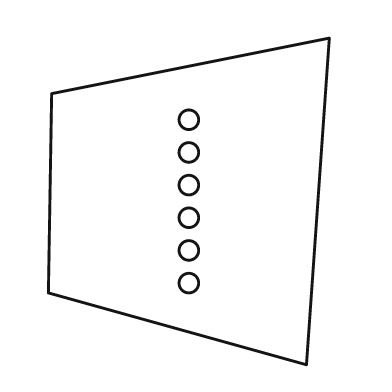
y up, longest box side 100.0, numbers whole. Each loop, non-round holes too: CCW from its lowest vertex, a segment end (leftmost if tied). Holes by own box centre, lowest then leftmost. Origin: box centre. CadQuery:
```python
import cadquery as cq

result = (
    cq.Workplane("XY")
    .moveTo(36.0, -50.0)
    .lineTo(43.0, 50.0)
    .lineTo(-42.0, 33.0)
    .lineTo(-43.0, -28.0)
    .close()
    .moveTo(0.0, -25.0)
    .circle(3.0)
    .moveTo(0.0, -15.0)
    .circle(3.0)
    .moveTo(0.0, -5.0)
    .circle(3.0)
    .moveTo(0.0, 5.0)
    .circle(3.0)
    .moveTo(0.0, 15.0)
    .circle(3.0)
    .moveTo(0.0, 25.0)
    .circle(3.0)
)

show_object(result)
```